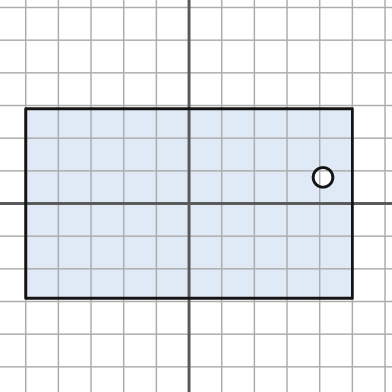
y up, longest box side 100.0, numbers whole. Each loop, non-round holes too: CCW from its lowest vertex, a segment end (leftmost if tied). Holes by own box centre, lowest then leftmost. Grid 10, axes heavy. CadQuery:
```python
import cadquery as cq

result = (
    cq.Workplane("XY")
    .moveTo(-50.0, -29.0)
    .lineTo(50.0, -29.0)
    .lineTo(50.0, 29.0)
    .lineTo(-50.0, 29.0)
    .close()
    .moveTo(41.0, 8.0)
    .circle(3.0)
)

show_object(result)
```